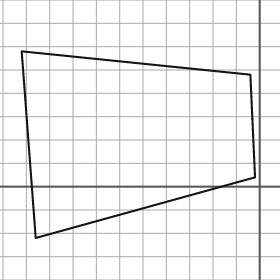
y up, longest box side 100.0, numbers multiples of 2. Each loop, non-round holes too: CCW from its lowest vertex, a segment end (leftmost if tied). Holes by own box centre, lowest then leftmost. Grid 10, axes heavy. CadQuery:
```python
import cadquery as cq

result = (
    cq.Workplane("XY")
    .moveTo(-96.0, -22.0)
    .lineTo(-2.0, 4.0)
    .lineTo(-4.0, 48.0)
    .lineTo(-102.0, 58.0)
    .close()
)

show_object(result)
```